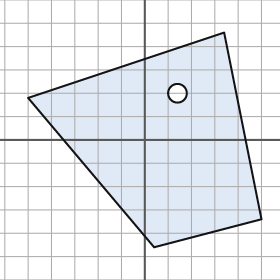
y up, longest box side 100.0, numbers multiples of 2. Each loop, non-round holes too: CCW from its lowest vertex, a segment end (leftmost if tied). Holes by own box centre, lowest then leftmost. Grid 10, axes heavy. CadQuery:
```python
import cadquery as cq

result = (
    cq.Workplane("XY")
    .moveTo(4.0, -46.0)
    .lineTo(50.0, -34.0)
    .lineTo(34.0, 46.0)
    .lineTo(-50.0, 18.0)
    .close()
    .moveTo(14.0, 20.0)
    .circle(4.0)
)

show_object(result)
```